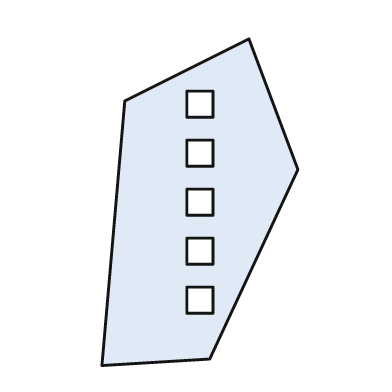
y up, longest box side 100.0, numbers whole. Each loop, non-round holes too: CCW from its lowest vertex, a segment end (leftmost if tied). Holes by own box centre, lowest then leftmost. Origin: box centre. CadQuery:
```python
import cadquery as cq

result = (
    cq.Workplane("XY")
    .moveTo(-30.0, -50.0)
    .lineTo(3.0, -48.0)
    .lineTo(30.0, 10.0)
    .lineTo(15.0, 50.0)
    .lineTo(-23.0, 31.0)
    .close()
    .moveTo(-4.0, -34.0)
    .lineTo(4.0, -34.0)
    .lineTo(4.0, -26.0)
    .lineTo(-4.0, -26.0)
    .close()
    .moveTo(-4.0, -19.0)
    .lineTo(4.0, -19.0)
    .lineTo(4.0, -11.0)
    .lineTo(-4.0, -11.0)
    .close()
    .moveTo(-4.0, -4.0)
    .lineTo(4.0, -4.0)
    .lineTo(4.0, 4.0)
    .lineTo(-4.0, 4.0)
    .close()
    .moveTo(-4.0, 11.0)
    .lineTo(4.0, 11.0)
    .lineTo(4.0, 19.0)
    .lineTo(-4.0, 19.0)
    .close()
    .moveTo(-4.0, 26.0)
    .lineTo(4.0, 26.0)
    .lineTo(4.0, 34.0)
    .lineTo(-4.0, 34.0)
    .close()
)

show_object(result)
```